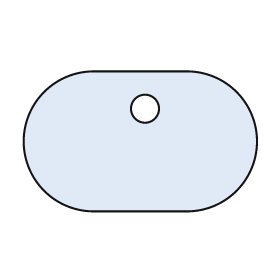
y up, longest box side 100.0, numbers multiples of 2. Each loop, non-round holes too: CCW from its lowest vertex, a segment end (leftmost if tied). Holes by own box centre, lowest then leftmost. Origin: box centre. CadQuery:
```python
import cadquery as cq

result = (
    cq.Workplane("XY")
    .moveTo(-20.0, -30.0)
    .lineTo(20.0, -30.0)
    .threePointArc((50.0, 0.0), (20.0, 30.0))
    .lineTo(-20.0, 30.0)
    .threePointArc((-50.0, 0.0), (-20.0, -30.0))
    .close()
    .moveTo(2.0, 14.0)
    .circle(6.0)
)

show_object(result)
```